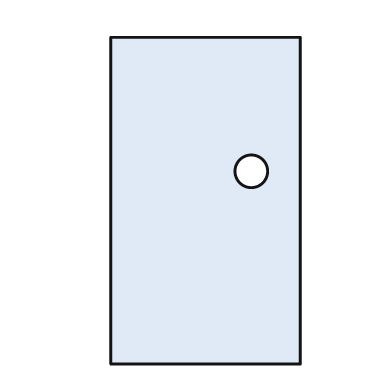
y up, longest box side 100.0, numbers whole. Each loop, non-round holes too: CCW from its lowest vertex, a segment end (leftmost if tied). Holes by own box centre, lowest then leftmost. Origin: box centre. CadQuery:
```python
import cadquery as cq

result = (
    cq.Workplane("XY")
    .moveTo(-29.0, -50.0)
    .lineTo(29.0, -50.0)
    .lineTo(29.0, 50.0)
    .lineTo(-29.0, 50.0)
    .close()
    .moveTo(14.0, 9.0)
    .circle(5.0)
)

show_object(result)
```